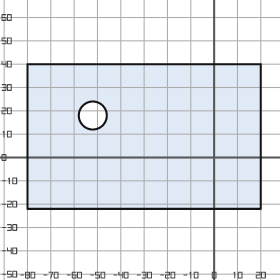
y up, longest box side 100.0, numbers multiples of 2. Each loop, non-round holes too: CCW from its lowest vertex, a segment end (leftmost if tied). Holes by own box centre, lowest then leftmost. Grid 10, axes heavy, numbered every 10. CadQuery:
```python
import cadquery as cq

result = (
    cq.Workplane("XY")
    .moveTo(-80.0, -22.0)
    .lineTo(20.0, -22.0)
    .lineTo(20.0, 40.0)
    .lineTo(-80.0, 40.0)
    .close()
    .moveTo(-52.0, 18.0)
    .circle(6.0)
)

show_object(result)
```